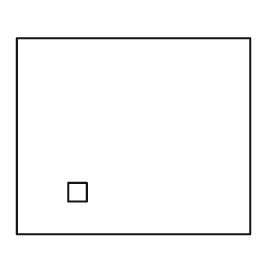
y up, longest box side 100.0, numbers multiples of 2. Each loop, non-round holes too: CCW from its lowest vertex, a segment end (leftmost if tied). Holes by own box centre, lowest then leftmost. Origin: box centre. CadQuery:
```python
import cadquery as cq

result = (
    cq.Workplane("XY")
    .moveTo(-50.0, -42.0)
    .lineTo(50.0, -42.0)
    .lineTo(50.0, 42.0)
    .lineTo(-50.0, 42.0)
    .close()
    .moveTo(-28.0, -28.0)
    .lineTo(-20.0, -28.0)
    .lineTo(-20.0, -20.0)
    .lineTo(-28.0, -20.0)
    .close()
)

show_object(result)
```